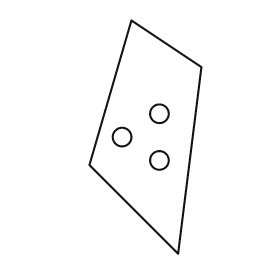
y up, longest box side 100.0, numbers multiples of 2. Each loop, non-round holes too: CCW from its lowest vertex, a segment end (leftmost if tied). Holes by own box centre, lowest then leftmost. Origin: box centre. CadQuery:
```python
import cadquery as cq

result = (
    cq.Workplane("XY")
    .moveTo(14.0, -50.0)
    .lineTo(24.0, 30.0)
    .lineTo(-6.0, 50.0)
    .lineTo(-24.0, -12.0)
    .close()
    .moveTo(6.0, -10.0)
    .circle(4.0)
    .moveTo(-10.0, 0.0)
    .circle(4.0)
    .moveTo(6.0, 10.0)
    .circle(4.0)
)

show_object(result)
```